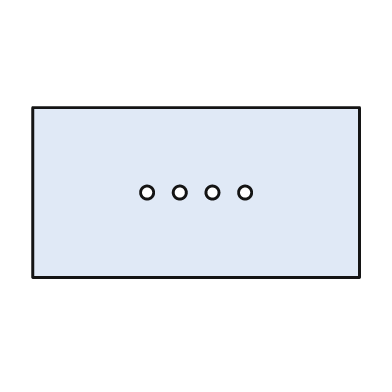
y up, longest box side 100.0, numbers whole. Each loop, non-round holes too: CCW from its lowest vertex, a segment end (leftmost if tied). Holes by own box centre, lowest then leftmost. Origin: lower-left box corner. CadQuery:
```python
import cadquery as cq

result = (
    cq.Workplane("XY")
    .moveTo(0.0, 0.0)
    .lineTo(100.0, 0.0)
    .lineTo(100.0, 52.0)
    .lineTo(0.0, 52.0)
    .close()
    .moveTo(35.0, 26.0)
    .circle(2.0)
    .moveTo(45.0, 26.0)
    .circle(2.0)
    .moveTo(55.0, 26.0)
    .circle(2.0)
    .moveTo(65.0, 26.0)
    .circle(2.0)
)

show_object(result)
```